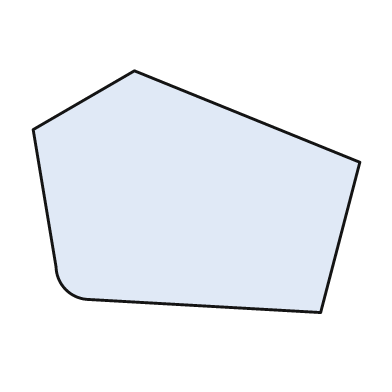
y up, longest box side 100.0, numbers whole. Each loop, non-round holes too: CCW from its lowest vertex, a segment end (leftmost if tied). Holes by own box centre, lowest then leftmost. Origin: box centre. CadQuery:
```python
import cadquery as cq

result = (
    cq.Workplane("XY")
    .moveTo(38.0, -37.0)
    .lineTo(50.0, 9.0)
    .lineTo(-19.0, 37.0)
    .lineTo(-50.0, 19.0)
    .lineTo(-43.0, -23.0)
    .threePointArc((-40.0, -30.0), (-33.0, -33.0))
    .close()
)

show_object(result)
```